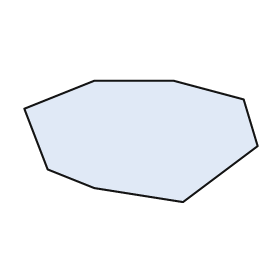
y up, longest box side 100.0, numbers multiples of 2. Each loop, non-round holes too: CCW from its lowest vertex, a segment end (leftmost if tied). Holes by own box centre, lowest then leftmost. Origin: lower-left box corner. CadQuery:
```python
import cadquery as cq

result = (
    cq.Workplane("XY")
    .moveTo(68.0, 0.0)
    .lineTo(100.0, 24.0)
    .lineTo(94.0, 44.0)
    .lineTo(64.0, 52.0)
    .lineTo(30.0, 52.0)
    .lineTo(0.0, 40.0)
    .lineTo(10.0, 14.0)
    .lineTo(30.0, 6.0)
    .close()
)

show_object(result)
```